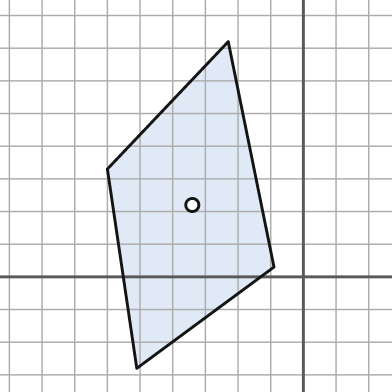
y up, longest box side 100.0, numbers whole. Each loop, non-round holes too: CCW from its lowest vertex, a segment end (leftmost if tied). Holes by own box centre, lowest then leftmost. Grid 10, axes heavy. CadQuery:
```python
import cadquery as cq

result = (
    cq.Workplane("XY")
    .moveTo(-51.0, -28.0)
    .lineTo(-9.0, 3.0)
    .lineTo(-23.0, 72.0)
    .lineTo(-60.0, 33.0)
    .close()
    .moveTo(-34.0, 22.0)
    .circle(2.0)
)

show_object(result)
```